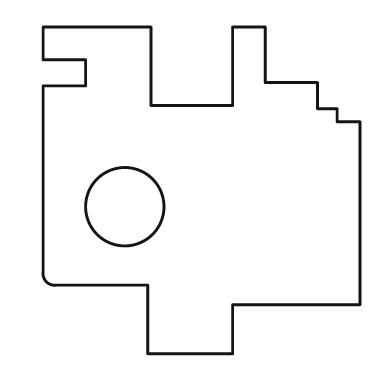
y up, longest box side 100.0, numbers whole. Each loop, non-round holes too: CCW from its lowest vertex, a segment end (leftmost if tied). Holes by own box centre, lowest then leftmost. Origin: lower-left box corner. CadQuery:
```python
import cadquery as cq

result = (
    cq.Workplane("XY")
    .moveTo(32.0, 0.0)
    .lineTo(58.0, 0.0)
    .lineTo(58.0, 15.0)
    .lineTo(97.0, 15.0)
    .lineTo(97.0, 71.0)
    .lineTo(90.0, 71.0)
    .lineTo(90.0, 75.0)
    .lineTo(84.0, 75.0)
    .lineTo(84.0, 83.0)
    .lineTo(68.0, 83.0)
    .lineTo(68.0, 100.0)
    .lineTo(58.0, 100.0)
    .lineTo(58.0, 76.0)
    .lineTo(33.0, 76.0)
    .lineTo(33.0, 100.0)
    .lineTo(0.0, 100.0)
    .lineTo(0.0, 90.0)
    .lineTo(13.0, 90.0)
    .lineTo(13.0, 82.0)
    .lineTo(0.0, 82.0)
    .lineTo(0.0, 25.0)
    .threePointArc((1.0, 22.0), (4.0, 21.0))
    .lineTo(32.0, 21.0)
    .close()
    .moveTo(25.0, 45.0)
    .circle(12.0)
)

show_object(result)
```